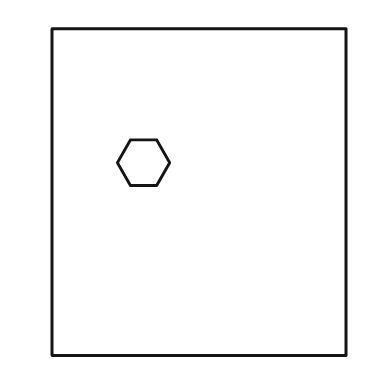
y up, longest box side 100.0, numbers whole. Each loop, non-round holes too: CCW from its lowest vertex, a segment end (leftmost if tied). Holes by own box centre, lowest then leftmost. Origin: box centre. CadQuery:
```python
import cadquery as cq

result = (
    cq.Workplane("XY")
    .moveTo(-45.0, -50.0)
    .lineTo(45.0, -50.0)
    .lineTo(45.0, 50.0)
    .lineTo(-45.0, 50.0)
    .close()
    .moveTo(-21.0, 2.0)
    .lineTo(-13.0, 2.0)
    .lineTo(-9.0, 9.0)
    .lineTo(-13.0, 16.0)
    .lineTo(-21.0, 16.0)
    .lineTo(-25.0, 9.0)
    .close()
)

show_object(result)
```